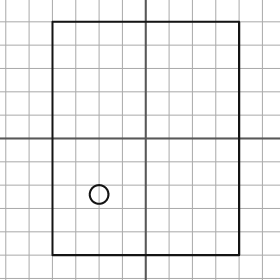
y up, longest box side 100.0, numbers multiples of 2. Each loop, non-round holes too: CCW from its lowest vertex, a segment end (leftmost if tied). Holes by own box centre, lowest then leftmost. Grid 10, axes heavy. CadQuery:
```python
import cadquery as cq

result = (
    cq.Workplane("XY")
    .moveTo(-40.0, -50.0)
    .lineTo(40.0, -50.0)
    .lineTo(40.0, 50.0)
    .lineTo(-40.0, 50.0)
    .close()
    .moveTo(-20.0, -24.0)
    .circle(4.0)
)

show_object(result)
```